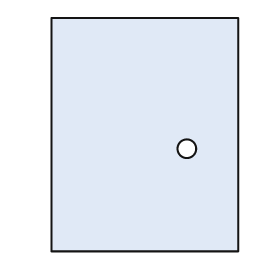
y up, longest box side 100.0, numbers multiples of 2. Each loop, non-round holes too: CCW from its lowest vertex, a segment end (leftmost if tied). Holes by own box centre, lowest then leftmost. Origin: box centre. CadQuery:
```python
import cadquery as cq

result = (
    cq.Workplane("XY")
    .moveTo(-40.0, -50.0)
    .lineTo(40.0, -50.0)
    .lineTo(40.0, 50.0)
    .lineTo(-40.0, 50.0)
    .close()
    .moveTo(18.0, -6.0)
    .circle(4.0)
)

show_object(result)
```